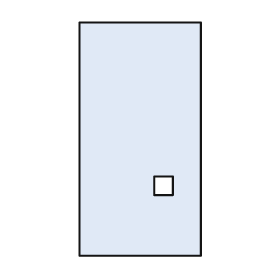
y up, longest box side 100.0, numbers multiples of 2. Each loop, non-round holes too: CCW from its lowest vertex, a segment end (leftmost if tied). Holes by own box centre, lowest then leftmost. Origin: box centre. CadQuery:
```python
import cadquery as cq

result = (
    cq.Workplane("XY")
    .moveTo(-26.0, -50.0)
    .lineTo(26.0, -50.0)
    .lineTo(26.0, 50.0)
    .lineTo(-26.0, 50.0)
    .close()
    .moveTo(6.0, -24.0)
    .lineTo(14.0, -24.0)
    .lineTo(14.0, -16.0)
    .lineTo(6.0, -16.0)
    .close()
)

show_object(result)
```